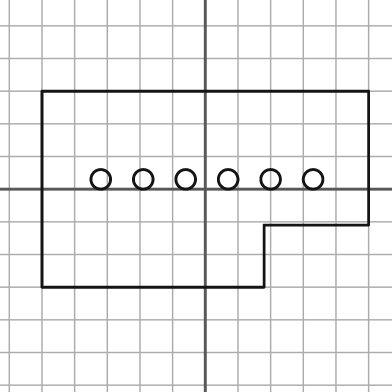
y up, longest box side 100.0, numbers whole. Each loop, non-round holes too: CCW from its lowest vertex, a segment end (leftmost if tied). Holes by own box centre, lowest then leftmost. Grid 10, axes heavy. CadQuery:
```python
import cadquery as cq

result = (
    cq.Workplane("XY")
    .moveTo(-50.0, -30.0)
    .lineTo(18.0, -30.0)
    .lineTo(18.0, -11.0)
    .lineTo(50.0, -11.0)
    .lineTo(50.0, 30.0)
    .lineTo(-50.0, 30.0)
    .close()
    .moveTo(-32.0, 3.0)
    .circle(3.0)
    .moveTo(-19.0, 3.0)
    .circle(3.0)
    .moveTo(-6.0, 3.0)
    .circle(3.0)
    .moveTo(7.0, 3.0)
    .circle(3.0)
    .moveTo(20.0, 3.0)
    .circle(3.0)
    .moveTo(33.0, 3.0)
    .circle(3.0)
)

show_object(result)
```